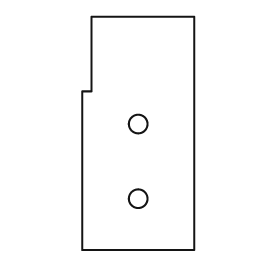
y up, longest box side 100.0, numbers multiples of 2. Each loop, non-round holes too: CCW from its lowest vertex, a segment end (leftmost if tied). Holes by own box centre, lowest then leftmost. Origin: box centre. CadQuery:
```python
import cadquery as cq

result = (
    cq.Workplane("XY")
    .moveTo(-24.0, -50.0)
    .lineTo(24.0, -50.0)
    .lineTo(24.0, 50.0)
    .lineTo(-20.0, 50.0)
    .lineTo(-20.0, 18.0)
    .lineTo(-24.0, 18.0)
    .close()
    .moveTo(0.0, -28.0)
    .circle(4.0)
    .moveTo(0.0, 4.0)
    .circle(4.0)
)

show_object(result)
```